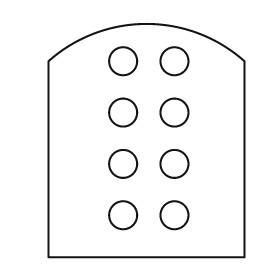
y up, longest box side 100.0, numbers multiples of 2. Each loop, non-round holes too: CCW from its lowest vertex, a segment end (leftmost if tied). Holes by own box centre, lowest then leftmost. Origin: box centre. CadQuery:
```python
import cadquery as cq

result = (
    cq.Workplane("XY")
    .moveTo(-42.0, -50.0)
    .lineTo(42.0, -50.0)
    .lineTo(42.0, 34.0)
    .threePointArc((0.0, 50.0), (-42.0, 34.0))
    .close()
    .moveTo(-10.0, -32.0)
    .circle(6.0)
    .moveTo(12.0, -32.0)
    .circle(6.0)
    .moveTo(-10.0, -10.0)
    .circle(6.0)
    .moveTo(12.0, -10.0)
    .circle(6.0)
    .moveTo(-10.0, 12.0)
    .circle(6.0)
    .moveTo(12.0, 12.0)
    .circle(6.0)
    .moveTo(-10.0, 34.0)
    .circle(6.0)
    .moveTo(12.0, 34.0)
    .circle(6.0)
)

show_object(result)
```